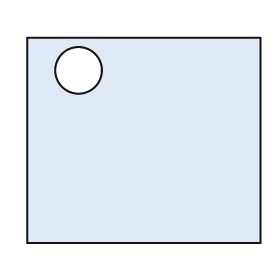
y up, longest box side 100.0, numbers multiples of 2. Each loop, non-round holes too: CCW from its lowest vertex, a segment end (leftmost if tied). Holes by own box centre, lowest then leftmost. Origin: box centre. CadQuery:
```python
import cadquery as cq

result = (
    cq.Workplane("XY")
    .moveTo(-50.0, -44.0)
    .lineTo(50.0, -44.0)
    .lineTo(50.0, 44.0)
    .lineTo(-50.0, 44.0)
    .close()
    .moveTo(-28.0, 30.0)
    .circle(10.0)
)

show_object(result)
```